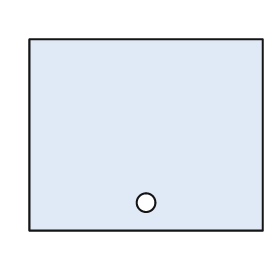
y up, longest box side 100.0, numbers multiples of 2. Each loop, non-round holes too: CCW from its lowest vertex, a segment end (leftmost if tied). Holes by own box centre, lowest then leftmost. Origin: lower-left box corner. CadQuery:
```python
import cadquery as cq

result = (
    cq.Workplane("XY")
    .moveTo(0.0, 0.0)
    .lineTo(100.0, 0.0)
    .lineTo(100.0, 82.0)
    .lineTo(0.0, 82.0)
    .close()
    .moveTo(50.0, 12.0)
    .circle(4.0)
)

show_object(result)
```